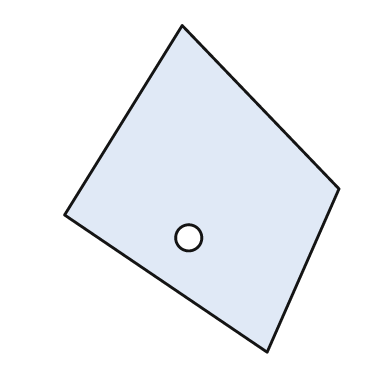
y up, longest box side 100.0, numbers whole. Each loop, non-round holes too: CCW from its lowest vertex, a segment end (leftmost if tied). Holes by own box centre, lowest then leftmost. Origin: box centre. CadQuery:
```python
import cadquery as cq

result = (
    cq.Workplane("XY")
    .moveTo(20.0, -50.0)
    .lineTo(42.0, 0.0)
    .lineTo(-6.0, 50.0)
    .lineTo(-42.0, -8.0)
    .close()
    .moveTo(-4.0, -15.0)
    .circle(4.0)
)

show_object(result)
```